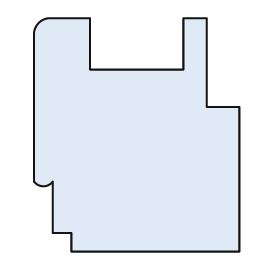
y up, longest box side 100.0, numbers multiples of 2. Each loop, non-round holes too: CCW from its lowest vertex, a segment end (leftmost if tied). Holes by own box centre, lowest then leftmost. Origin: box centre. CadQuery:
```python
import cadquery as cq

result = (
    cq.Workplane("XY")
    .moveTo(-28.0, -50.0)
    .lineTo(44.0, -50.0)
    .lineTo(44.0, 12.0)
    .lineTo(30.0, 12.0)
    .lineTo(30.0, 50.0)
    .lineTo(20.0, 50.0)
    .lineTo(20.0, 28.0)
    .lineTo(-20.0, 28.0)
    .lineTo(-20.0, 50.0)
    .lineTo(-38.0, 50.0)
    .threePointArc((-42.0, 48.0), (-44.0, 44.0))
    .lineTo(-44.0, -20.0)
    .threePointArc((-40.0, -22.0), (-36.0, -20.0))
    .lineTo(-36.0, -42.0)
    .lineTo(-28.0, -42.0)
    .close()
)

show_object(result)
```